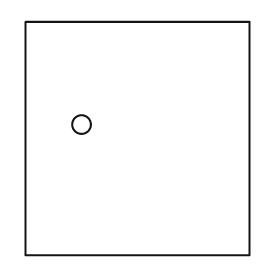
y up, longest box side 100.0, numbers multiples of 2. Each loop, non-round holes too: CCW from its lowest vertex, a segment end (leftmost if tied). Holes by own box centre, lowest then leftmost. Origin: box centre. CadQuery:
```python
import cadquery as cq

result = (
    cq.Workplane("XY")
    .moveTo(-48.0, -50.0)
    .lineTo(48.0, -50.0)
    .lineTo(48.0, 50.0)
    .lineTo(-48.0, 50.0)
    .close()
    .moveTo(-24.0, 6.0)
    .circle(4.0)
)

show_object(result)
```